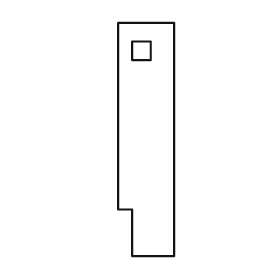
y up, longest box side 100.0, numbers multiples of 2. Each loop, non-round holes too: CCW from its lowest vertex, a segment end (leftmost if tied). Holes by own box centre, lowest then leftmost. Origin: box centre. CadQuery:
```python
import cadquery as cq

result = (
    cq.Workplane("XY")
    .moveTo(-6.0, -50.0)
    .lineTo(12.0, -50.0)
    .lineTo(12.0, 50.0)
    .lineTo(-12.0, 50.0)
    .lineTo(-12.0, -30.0)
    .lineTo(-6.0, -30.0)
    .close()
    .moveTo(-6.0, 34.0)
    .lineTo(2.0, 34.0)
    .lineTo(2.0, 42.0)
    .lineTo(-6.0, 42.0)
    .close()
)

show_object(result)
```